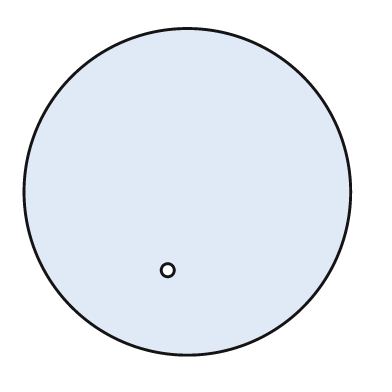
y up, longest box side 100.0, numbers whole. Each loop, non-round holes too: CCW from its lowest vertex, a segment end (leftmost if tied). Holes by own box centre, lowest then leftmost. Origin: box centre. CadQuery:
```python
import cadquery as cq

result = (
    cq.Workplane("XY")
    .moveTo(0.0, 0.0)
    .circle(50.0)
    .moveTo(-6.0, -24.0)
    .circle(2.0)
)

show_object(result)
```